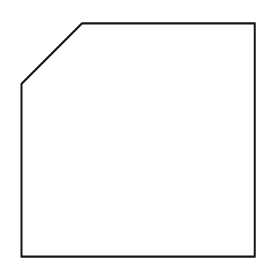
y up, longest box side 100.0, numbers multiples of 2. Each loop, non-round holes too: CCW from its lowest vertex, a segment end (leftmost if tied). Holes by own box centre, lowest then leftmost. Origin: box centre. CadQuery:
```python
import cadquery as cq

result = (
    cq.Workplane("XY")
    .moveTo(-50.0, -50.0)
    .lineTo(50.0, -50.0)
    .lineTo(50.0, 50.0)
    .lineTo(-24.0, 50.0)
    .lineTo(-50.0, 24.0)
    .close()
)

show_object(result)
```